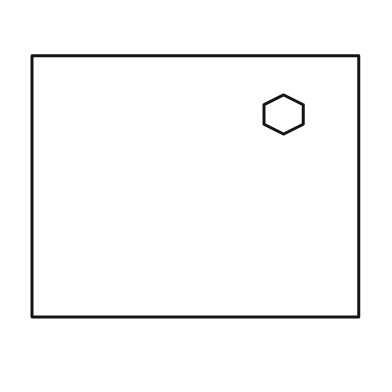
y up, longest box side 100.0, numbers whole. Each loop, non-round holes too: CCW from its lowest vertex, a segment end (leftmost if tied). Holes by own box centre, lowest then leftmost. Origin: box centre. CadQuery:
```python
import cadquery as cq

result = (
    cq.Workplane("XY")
    .moveTo(-50.0, -40.0)
    .lineTo(50.0, -40.0)
    .lineTo(50.0, 40.0)
    .lineTo(-50.0, 40.0)
    .close()
    .moveTo(27.0, 16.0)
    .lineTo(33.0, 19.0)
    .lineTo(33.0, 25.0)
    .lineTo(27.0, 28.0)
    .lineTo(21.0, 25.0)
    .lineTo(21.0, 19.0)
    .close()
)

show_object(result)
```